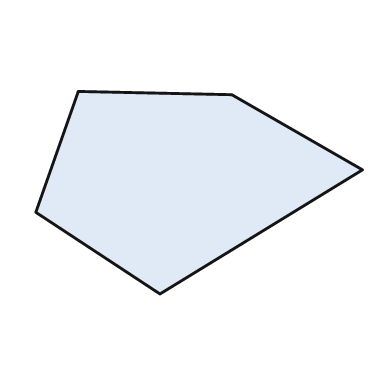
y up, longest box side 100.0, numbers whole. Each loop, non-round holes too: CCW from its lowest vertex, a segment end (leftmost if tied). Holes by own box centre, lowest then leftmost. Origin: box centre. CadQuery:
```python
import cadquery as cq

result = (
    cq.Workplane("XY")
    .moveTo(-12.0, -31.0)
    .lineTo(50.0, 7.0)
    .lineTo(10.0, 30.0)
    .lineTo(-37.0, 31.0)
    .lineTo(-50.0, -6.0)
    .close()
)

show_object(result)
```